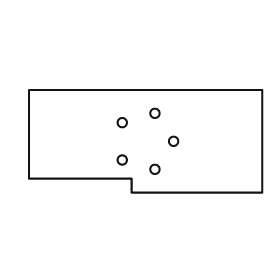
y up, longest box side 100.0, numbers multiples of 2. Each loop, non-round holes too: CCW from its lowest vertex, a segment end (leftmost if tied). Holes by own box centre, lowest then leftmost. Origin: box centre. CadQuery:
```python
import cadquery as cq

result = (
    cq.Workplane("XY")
    .moveTo(-6.0, -22.0)
    .lineTo(50.0, -22.0)
    .lineTo(50.0, 22.0)
    .lineTo(-50.0, 22.0)
    .lineTo(-50.0, -16.0)
    .lineTo(-6.0, -16.0)
    .close()
    .moveTo(4.0, -12.0)
    .circle(2.0)
    .moveTo(-10.0, -8.0)
    .circle(2.0)
    .moveTo(12.0, 0.0)
    .circle(2.0)
    .moveTo(-10.0, 8.0)
    .circle(2.0)
    .moveTo(4.0, 12.0)
    .circle(2.0)
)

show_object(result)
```